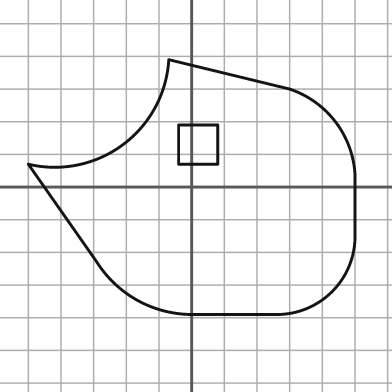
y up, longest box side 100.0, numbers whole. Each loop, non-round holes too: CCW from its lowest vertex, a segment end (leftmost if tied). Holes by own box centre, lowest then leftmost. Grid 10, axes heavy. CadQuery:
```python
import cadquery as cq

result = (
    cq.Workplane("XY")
    .moveTo(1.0, -39.0)
    .lineTo(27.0, -39.0)
    .threePointArc((43.0, -32.0), (50.0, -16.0))
    .lineTo(50.0, 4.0)
    .threePointArc((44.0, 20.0), (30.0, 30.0))
    .lineTo(-7.0, 39.0)
    .threePointArc((-21.0, 13.0), (-50.0, 7.0))
    .lineTo(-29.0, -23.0)
    .threePointArc((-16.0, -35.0), (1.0, -39.0))
    .close()
    .moveTo(-4.0, 7.0)
    .lineTo(8.0, 7.0)
    .lineTo(8.0, 19.0)
    .lineTo(-4.0, 19.0)
    .close()
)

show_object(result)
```